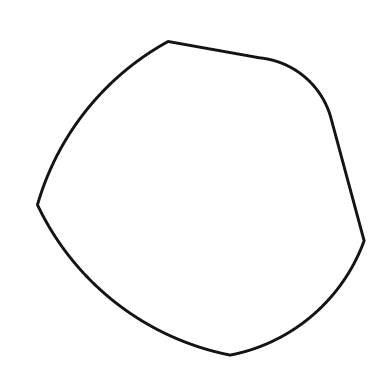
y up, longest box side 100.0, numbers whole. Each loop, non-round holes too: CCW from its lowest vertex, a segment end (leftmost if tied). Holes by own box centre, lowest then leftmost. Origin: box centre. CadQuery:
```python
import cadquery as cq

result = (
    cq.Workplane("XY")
    .moveTo(9.0, -48.0)
    .threePointArc((34.0, -36.0), (50.0, -13.0))
    .lineTo(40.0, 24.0)
    .threePointArc((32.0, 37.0), (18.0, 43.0))
    .lineTo(-10.0, 48.0)
    .threePointArc((-35.0, 27.0), (-50.0, -2.0))
    .threePointArc((-26.0, -32.0), (9.0, -48.0))
    .close()
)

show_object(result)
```